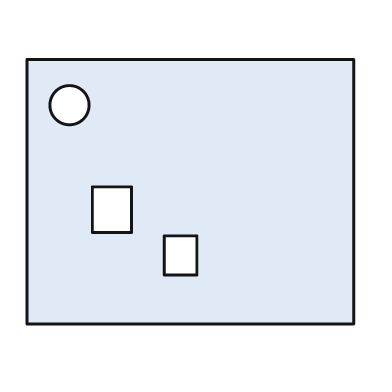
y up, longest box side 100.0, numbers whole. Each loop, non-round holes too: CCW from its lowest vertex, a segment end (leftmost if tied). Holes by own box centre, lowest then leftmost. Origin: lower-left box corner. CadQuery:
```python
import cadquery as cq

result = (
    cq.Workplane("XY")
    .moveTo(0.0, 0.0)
    .lineTo(100.0, 0.0)
    .lineTo(100.0, 81.0)
    .lineTo(0.0, 81.0)
    .close()
    .moveTo(42.0, 15.0)
    .lineTo(52.0, 15.0)
    .lineTo(52.0, 27.0)
    .lineTo(42.0, 27.0)
    .close()
    .moveTo(20.0, 28.0)
    .lineTo(32.0, 28.0)
    .lineTo(32.0, 42.0)
    .lineTo(20.0, 42.0)
    .close()
    .moveTo(13.0, 67.0)
    .circle(6.0)
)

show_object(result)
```